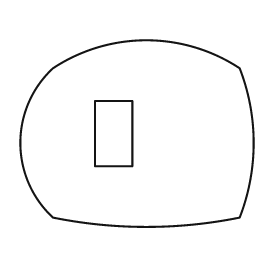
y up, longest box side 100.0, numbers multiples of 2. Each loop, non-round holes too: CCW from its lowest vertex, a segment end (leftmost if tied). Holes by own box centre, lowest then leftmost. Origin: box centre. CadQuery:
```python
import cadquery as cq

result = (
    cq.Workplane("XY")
    .moveTo(-36.0, -36.0)
    .threePointArc((4.0, -40.0), (44.0, -36.0))
    .threePointArc((50.0, -4.0), (44.0, 28.0))
    .threePointArc((4.0, 40.0), (-36.0, 28.0))
    .threePointArc((-50.0, -4.0), (-36.0, -36.0))
    .close()
    .moveTo(-18.0, -14.0)
    .lineTo(-2.0, -14.0)
    .lineTo(-2.0, 14.0)
    .lineTo(-18.0, 14.0)
    .close()
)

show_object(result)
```